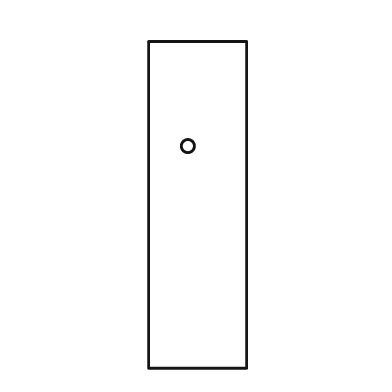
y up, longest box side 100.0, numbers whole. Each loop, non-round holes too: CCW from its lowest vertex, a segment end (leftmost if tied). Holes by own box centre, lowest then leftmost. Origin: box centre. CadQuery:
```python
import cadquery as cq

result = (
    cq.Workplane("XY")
    .moveTo(-15.0, -50.0)
    .lineTo(15.0, -50.0)
    .lineTo(15.0, 50.0)
    .lineTo(-15.0, 50.0)
    .close()
    .moveTo(-3.0, 18.0)
    .circle(2.0)
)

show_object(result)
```